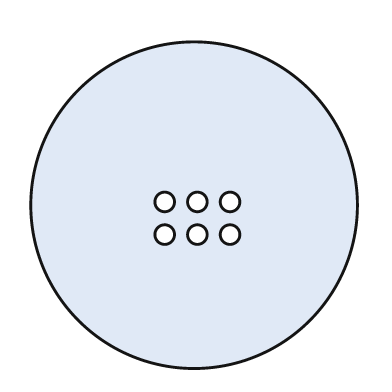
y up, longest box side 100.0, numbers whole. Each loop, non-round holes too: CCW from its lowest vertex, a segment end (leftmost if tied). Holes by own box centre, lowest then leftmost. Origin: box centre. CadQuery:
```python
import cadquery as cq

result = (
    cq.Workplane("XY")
    .moveTo(0.0, 0.0)
    .circle(50.0)
    .moveTo(-9.0, -9.0)
    .circle(3.0)
    .moveTo(1.0, -9.0)
    .circle(3.0)
    .moveTo(11.0, -9.0)
    .circle(3.0)
    .moveTo(-9.0, 1.0)
    .circle(3.0)
    .moveTo(1.0, 1.0)
    .circle(3.0)
    .moveTo(11.0, 1.0)
    .circle(3.0)
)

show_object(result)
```